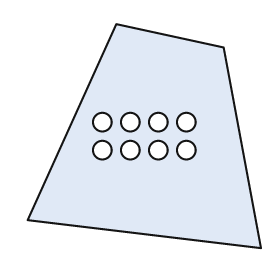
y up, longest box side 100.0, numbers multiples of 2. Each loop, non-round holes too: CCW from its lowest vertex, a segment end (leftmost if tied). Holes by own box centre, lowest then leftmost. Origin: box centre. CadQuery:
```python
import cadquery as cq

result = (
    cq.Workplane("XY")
    .moveTo(50.0, -48.0)
    .lineTo(34.0, 38.0)
    .lineTo(-12.0, 48.0)
    .lineTo(-50.0, -36.0)
    .close()
    .moveTo(-18.0, -6.0)
    .circle(4.0)
    .moveTo(-6.0, -6.0)
    .circle(4.0)
    .moveTo(6.0, -6.0)
    .circle(4.0)
    .moveTo(18.0, -6.0)
    .circle(4.0)
    .moveTo(-18.0, 6.0)
    .circle(4.0)
    .moveTo(-6.0, 6.0)
    .circle(4.0)
    .moveTo(6.0, 6.0)
    .circle(4.0)
    .moveTo(18.0, 6.0)
    .circle(4.0)
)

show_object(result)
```